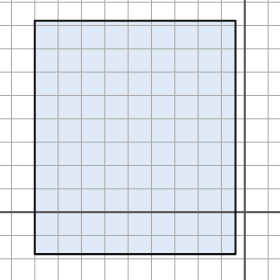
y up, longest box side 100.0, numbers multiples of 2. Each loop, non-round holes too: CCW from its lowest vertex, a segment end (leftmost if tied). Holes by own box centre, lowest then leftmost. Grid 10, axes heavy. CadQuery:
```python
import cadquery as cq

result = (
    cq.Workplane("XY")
    .moveTo(-90.0, -18.0)
    .lineTo(-4.0, -18.0)
    .lineTo(-4.0, 82.0)
    .lineTo(-90.0, 82.0)
    .close()
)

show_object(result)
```